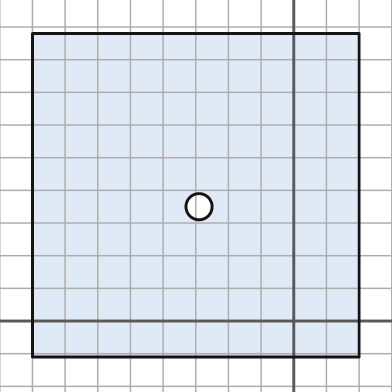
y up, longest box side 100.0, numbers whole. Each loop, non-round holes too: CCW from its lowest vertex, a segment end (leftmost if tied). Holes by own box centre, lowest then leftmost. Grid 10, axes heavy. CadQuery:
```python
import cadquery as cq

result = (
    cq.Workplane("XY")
    .moveTo(-80.0, -11.0)
    .lineTo(20.0, -11.0)
    .lineTo(20.0, 88.0)
    .lineTo(-80.0, 88.0)
    .close()
    .moveTo(-29.0, 35.0)
    .circle(4.0)
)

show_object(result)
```